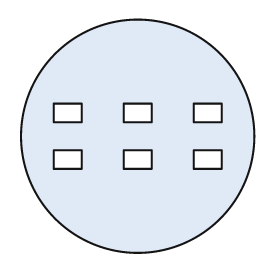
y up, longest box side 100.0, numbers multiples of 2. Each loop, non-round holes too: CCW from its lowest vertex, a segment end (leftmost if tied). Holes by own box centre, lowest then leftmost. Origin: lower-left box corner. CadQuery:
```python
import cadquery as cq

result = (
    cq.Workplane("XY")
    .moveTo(50.0, 50.0)
    .circle(50.0)
    .moveTo(14.0, 36.0)
    .lineTo(26.0, 36.0)
    .lineTo(26.0, 44.0)
    .lineTo(14.0, 44.0)
    .close()
    .moveTo(44.0, 36.0)
    .lineTo(56.0, 36.0)
    .lineTo(56.0, 44.0)
    .lineTo(44.0, 44.0)
    .close()
    .moveTo(74.0, 36.0)
    .lineTo(86.0, 36.0)
    .lineTo(86.0, 44.0)
    .lineTo(74.0, 44.0)
    .close()
    .moveTo(14.0, 56.0)
    .lineTo(26.0, 56.0)
    .lineTo(26.0, 64.0)
    .lineTo(14.0, 64.0)
    .close()
    .moveTo(44.0, 56.0)
    .lineTo(56.0, 56.0)
    .lineTo(56.0, 64.0)
    .lineTo(44.0, 64.0)
    .close()
    .moveTo(74.0, 56.0)
    .lineTo(86.0, 56.0)
    .lineTo(86.0, 64.0)
    .lineTo(74.0, 64.0)
    .close()
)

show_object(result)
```